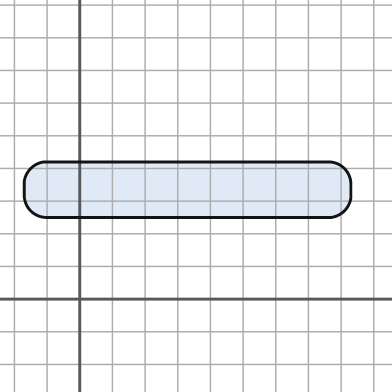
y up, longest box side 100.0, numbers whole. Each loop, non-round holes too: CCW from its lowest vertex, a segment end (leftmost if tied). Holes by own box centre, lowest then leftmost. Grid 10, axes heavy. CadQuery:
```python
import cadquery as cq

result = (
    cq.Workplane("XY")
    .moveTo(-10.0, 25.0)
    .lineTo(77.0, 25.0)
    .threePointArc((81.0, 27.0), (83.0, 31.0))
    .lineTo(83.0, 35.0)
    .threePointArc((81.0, 40.0), (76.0, 42.0))
    .lineTo(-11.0, 42.0)
    .threePointArc((-15.0, 40.0), (-17.0, 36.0))
    .lineTo(-17.0, 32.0)
    .threePointArc((-15.0, 27.0), (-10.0, 25.0))
    .close()
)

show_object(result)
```